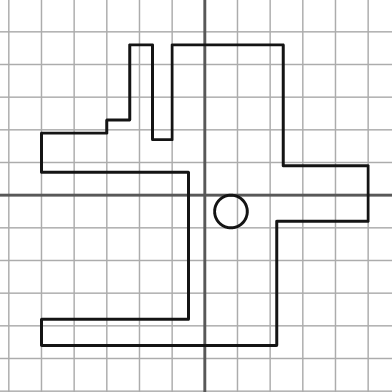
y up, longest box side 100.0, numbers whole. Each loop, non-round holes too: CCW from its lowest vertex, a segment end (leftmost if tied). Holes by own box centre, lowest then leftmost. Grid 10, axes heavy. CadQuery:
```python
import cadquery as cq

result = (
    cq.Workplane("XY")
    .moveTo(-50.0, -46.0)
    .lineTo(22.0, -46.0)
    .lineTo(22.0, -8.0)
    .lineTo(50.0, -8.0)
    .lineTo(50.0, 9.0)
    .lineTo(24.0, 9.0)
    .lineTo(24.0, 46.0)
    .lineTo(-10.0, 46.0)
    .lineTo(-10.0, 17.0)
    .lineTo(-16.0, 17.0)
    .lineTo(-16.0, 46.0)
    .lineTo(-23.0, 46.0)
    .lineTo(-23.0, 23.0)
    .lineTo(-30.0, 23.0)
    .lineTo(-30.0, 19.0)
    .lineTo(-50.0, 19.0)
    .lineTo(-50.0, 7.0)
    .lineTo(-5.0, 7.0)
    .lineTo(-5.0, -38.0)
    .lineTo(-50.0, -38.0)
    .close()
    .moveTo(8.0, -5.0)
    .circle(5.0)
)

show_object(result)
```